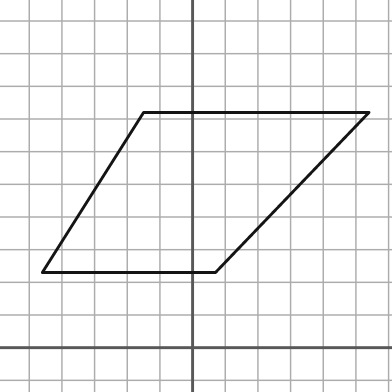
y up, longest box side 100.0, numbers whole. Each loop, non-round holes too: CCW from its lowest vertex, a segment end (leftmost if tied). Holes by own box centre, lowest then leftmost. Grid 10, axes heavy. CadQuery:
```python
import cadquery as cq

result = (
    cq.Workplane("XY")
    .moveTo(-46.0, 23.0)
    .lineTo(7.0, 23.0)
    .lineTo(54.0, 72.0)
    .lineTo(-15.0, 72.0)
    .close()
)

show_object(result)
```